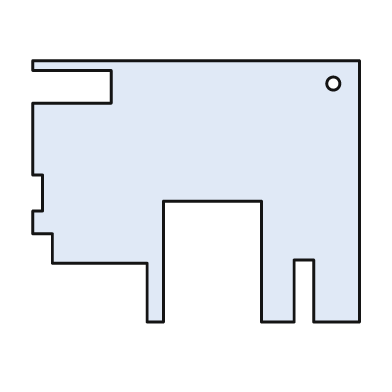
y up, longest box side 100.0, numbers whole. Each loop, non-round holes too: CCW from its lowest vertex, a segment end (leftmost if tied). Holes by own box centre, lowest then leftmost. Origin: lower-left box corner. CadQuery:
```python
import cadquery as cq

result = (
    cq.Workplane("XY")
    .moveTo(35.0, 0.0)
    .lineTo(40.0, 0.0)
    .lineTo(40.0, 37.0)
    .lineTo(70.0, 37.0)
    .lineTo(70.0, 0.0)
    .lineTo(80.0, 0.0)
    .lineTo(80.0, 19.0)
    .lineTo(86.0, 19.0)
    .lineTo(86.0, 0.0)
    .lineTo(100.0, 0.0)
    .lineTo(100.0, 80.0)
    .lineTo(0.0, 80.0)
    .lineTo(0.0, 77.0)
    .lineTo(24.0, 77.0)
    .lineTo(24.0, 67.0)
    .lineTo(0.0, 67.0)
    .lineTo(0.0, 45.0)
    .lineTo(3.0, 45.0)
    .lineTo(3.0, 34.0)
    .lineTo(0.0, 34.0)
    .lineTo(0.0, 27.0)
    .lineTo(6.0, 27.0)
    .lineTo(6.0, 18.0)
    .lineTo(35.0, 18.0)
    .close()
    .moveTo(92.0, 73.0)
    .circle(2.0)
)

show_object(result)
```